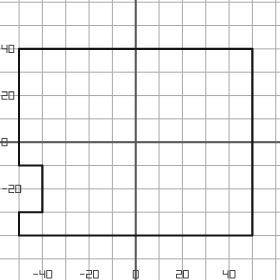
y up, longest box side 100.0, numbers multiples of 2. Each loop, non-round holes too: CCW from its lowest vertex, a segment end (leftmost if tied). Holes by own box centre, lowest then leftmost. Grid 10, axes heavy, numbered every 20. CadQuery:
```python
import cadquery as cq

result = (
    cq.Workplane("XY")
    .moveTo(-50.0, -40.0)
    .lineTo(50.0, -40.0)
    .lineTo(50.0, 40.0)
    .lineTo(-50.0, 40.0)
    .lineTo(-50.0, -10.0)
    .lineTo(-40.0, -10.0)
    .lineTo(-40.0, -30.0)
    .lineTo(-50.0, -30.0)
    .close()
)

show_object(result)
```